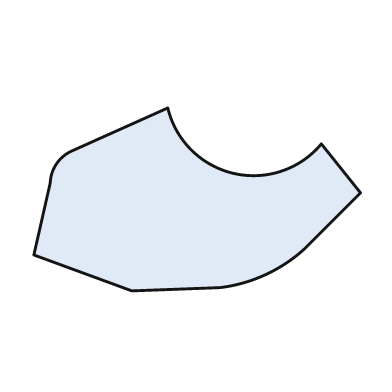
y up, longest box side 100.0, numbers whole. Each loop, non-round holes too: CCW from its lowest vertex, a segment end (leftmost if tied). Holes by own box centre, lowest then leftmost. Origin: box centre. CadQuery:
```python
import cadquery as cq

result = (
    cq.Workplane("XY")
    .moveTo(-20.0, -28.0)
    .lineTo(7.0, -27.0)
    .threePointArc((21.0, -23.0), (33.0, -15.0))
    .lineTo(50.0, 2.0)
    .lineTo(38.0, 17.0)
    .threePointArc((11.0, 8.0), (-9.0, 28.0))
    .lineTo(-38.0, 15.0)
    .threePointArc((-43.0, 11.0), (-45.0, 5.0))
    .lineTo(-50.0, -17.0)
    .close()
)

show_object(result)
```